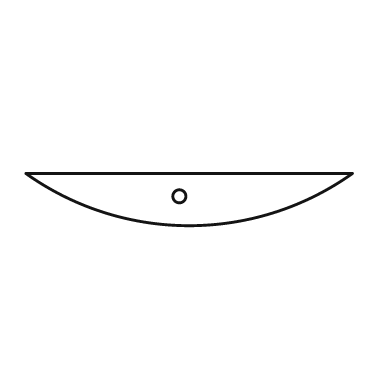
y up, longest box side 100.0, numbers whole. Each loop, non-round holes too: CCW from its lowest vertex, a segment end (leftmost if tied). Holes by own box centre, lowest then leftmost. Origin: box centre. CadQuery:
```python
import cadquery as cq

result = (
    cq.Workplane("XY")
    .moveTo(-50.0, 8.0)
    .threePointArc((0.0, -8.0), (50.0, 8.0))
    .close()
    .moveTo(-3.0, 1.0)
    .circle(2.0)
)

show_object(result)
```